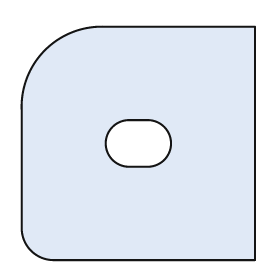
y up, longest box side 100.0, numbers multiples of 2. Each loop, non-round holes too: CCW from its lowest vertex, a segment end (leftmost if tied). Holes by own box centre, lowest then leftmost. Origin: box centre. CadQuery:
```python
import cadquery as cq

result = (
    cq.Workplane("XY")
    .moveTo(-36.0, -50.0)
    .lineTo(50.0, -50.0)
    .lineTo(50.0, 50.0)
    .lineTo(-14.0, 50.0)
    .threePointArc((-40.0, 40.0), (-50.0, 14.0))
    .lineTo(-50.0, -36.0)
    .threePointArc((-46.0, -46.0), (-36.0, -50.0))
    .close()
    .moveTo(-4.0, -10.0)
    .lineTo(4.0, -10.0)
    .threePointArc((14.0, 0.0), (4.0, 10.0))
    .lineTo(-4.0, 10.0)
    .threePointArc((-14.0, 0.0), (-4.0, -10.0))
    .close()
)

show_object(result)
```